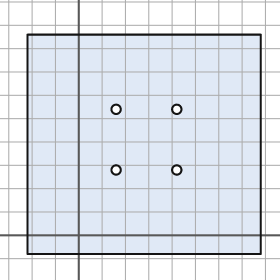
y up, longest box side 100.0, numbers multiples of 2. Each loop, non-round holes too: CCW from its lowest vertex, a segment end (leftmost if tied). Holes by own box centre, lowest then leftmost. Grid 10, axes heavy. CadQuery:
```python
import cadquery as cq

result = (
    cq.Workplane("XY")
    .moveTo(-22.0, -8.0)
    .lineTo(78.0, -8.0)
    .lineTo(78.0, 86.0)
    .lineTo(-22.0, 86.0)
    .close()
    .moveTo(16.0, 28.0)
    .circle(2.0)
    .moveTo(42.0, 28.0)
    .circle(2.0)
    .moveTo(16.0, 54.0)
    .circle(2.0)
    .moveTo(42.0, 54.0)
    .circle(2.0)
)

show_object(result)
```